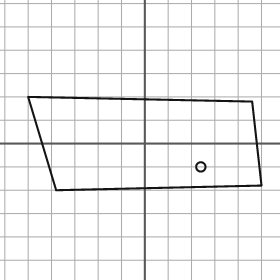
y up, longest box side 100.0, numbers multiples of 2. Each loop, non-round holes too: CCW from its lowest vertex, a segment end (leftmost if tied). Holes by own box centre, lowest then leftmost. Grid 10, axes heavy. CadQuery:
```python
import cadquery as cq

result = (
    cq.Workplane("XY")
    .moveTo(-38.0, -20.0)
    .lineTo(50.0, -18.0)
    .lineTo(46.0, 18.0)
    .lineTo(-50.0, 20.0)
    .close()
    .moveTo(24.0, -10.0)
    .circle(2.0)
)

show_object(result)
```